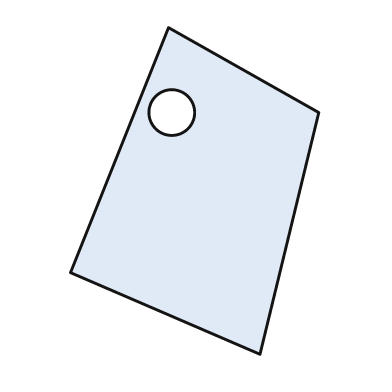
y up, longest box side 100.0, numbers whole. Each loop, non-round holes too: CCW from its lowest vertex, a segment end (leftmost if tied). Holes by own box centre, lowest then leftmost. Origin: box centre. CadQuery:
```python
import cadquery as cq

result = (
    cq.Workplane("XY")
    .moveTo(20.0, -50.0)
    .lineTo(38.0, 24.0)
    .lineTo(-8.0, 50.0)
    .lineTo(-38.0, -25.0)
    .close()
    .moveTo(-7.0, 24.0)
    .circle(7.0)
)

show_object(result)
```